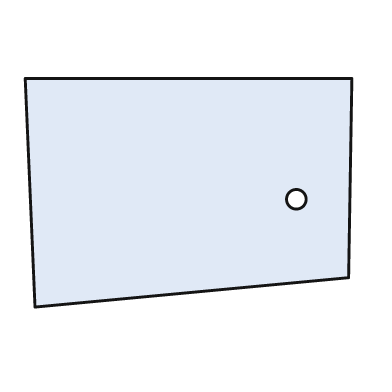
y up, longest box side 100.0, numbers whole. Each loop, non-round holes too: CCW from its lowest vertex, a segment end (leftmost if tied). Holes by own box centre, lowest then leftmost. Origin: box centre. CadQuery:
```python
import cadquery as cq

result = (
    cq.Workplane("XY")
    .moveTo(-47.0, -35.0)
    .lineTo(49.0, -26.0)
    .lineTo(50.0, 35.0)
    .lineTo(-50.0, 35.0)
    .close()
    .moveTo(33.0, -2.0)
    .circle(3.0)
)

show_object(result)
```